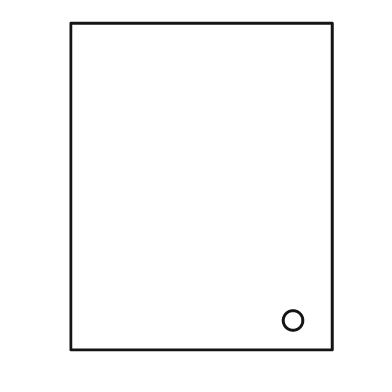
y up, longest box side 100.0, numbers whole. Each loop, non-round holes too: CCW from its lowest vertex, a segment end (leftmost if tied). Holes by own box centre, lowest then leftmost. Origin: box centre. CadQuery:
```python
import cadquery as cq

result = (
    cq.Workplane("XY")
    .moveTo(-40.0, -50.0)
    .lineTo(40.0, -50.0)
    .lineTo(40.0, 50.0)
    .lineTo(-40.0, 50.0)
    .close()
    .moveTo(28.0, -41.0)
    .circle(3.0)
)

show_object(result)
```